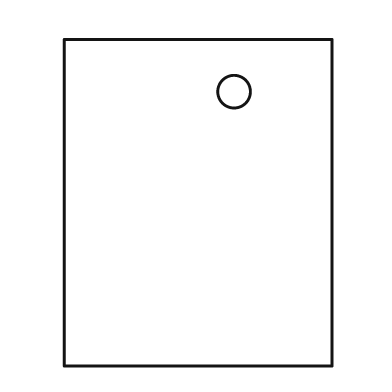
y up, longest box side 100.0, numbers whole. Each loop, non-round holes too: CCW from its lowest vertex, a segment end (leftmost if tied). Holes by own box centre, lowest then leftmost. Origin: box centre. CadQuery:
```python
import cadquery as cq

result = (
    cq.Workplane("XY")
    .moveTo(-41.0, -50.0)
    .lineTo(41.0, -50.0)
    .lineTo(41.0, 50.0)
    .lineTo(-41.0, 50.0)
    .close()
    .moveTo(11.0, 34.0)
    .circle(5.0)
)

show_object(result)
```